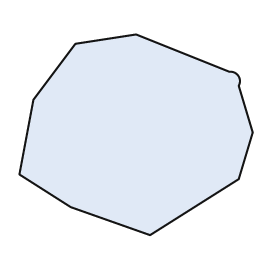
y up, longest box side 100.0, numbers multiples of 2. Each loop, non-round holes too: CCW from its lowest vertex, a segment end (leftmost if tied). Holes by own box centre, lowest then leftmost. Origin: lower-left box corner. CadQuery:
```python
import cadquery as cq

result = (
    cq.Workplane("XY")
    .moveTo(56.0, 0.0)
    .lineTo(94.0, 24.0)
    .lineTo(100.0, 44.0)
    .lineTo(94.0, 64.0)
    .threePointArc((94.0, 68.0), (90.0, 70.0))
    .lineTo(50.0, 86.0)
    .lineTo(24.0, 82.0)
    .lineTo(6.0, 58.0)
    .lineTo(0.0, 26.0)
    .lineTo(22.0, 12.0)
    .close()
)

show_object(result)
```